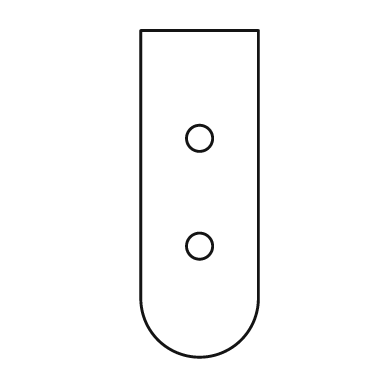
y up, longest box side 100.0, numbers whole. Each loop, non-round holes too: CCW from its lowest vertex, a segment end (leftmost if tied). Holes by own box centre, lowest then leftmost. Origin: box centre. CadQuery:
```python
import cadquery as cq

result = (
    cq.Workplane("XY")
    .moveTo(-18.0, -32.0)
    .threePointArc((0.0, -50.0), (18.0, -32.0))
    .lineTo(18.0, 50.0)
    .lineTo(-18.0, 50.0)
    .close()
    .moveTo(0.0, -16.0)
    .circle(4.0)
    .moveTo(0.0, 17.0)
    .circle(4.0)
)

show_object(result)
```